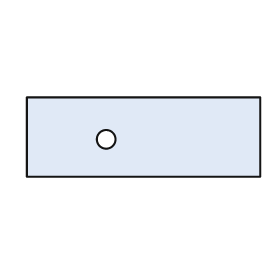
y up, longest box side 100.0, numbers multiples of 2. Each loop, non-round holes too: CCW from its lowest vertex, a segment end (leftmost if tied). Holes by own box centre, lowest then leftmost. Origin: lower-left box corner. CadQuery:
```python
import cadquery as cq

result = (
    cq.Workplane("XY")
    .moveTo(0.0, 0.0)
    .lineTo(100.0, 0.0)
    .lineTo(100.0, 34.0)
    .lineTo(0.0, 34.0)
    .close()
    .moveTo(34.0, 16.0)
    .circle(4.0)
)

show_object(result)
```